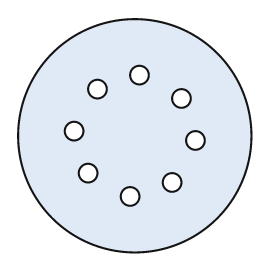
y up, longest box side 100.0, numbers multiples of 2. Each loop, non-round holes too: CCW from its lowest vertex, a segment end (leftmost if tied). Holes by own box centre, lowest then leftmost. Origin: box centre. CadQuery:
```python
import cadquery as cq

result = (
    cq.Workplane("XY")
    .moveTo(0.0, 0.0)
    .circle(50.0)
    .moveTo(-2.0, -26.0)
    .circle(4.0)
    .moveTo(16.0, -20.0)
    .circle(4.0)
    .moveTo(-20.0, -16.0)
    .circle(4.0)
    .moveTo(26.0, -2.0)
    .circle(4.0)
    .moveTo(-26.0, 2.0)
    .circle(4.0)
    .moveTo(20.0, 16.0)
    .circle(4.0)
    .moveTo(-16.0, 20.0)
    .circle(4.0)
    .moveTo(2.0, 26.0)
    .circle(4.0)
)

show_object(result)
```